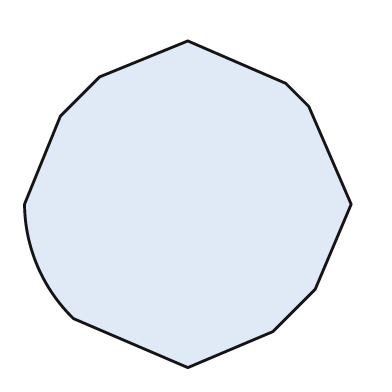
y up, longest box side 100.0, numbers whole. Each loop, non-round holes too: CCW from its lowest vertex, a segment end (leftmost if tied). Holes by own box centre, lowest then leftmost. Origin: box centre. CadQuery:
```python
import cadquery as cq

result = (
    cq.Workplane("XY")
    .moveTo(0.0, -50.0)
    .lineTo(26.0, -39.0)
    .lineTo(39.0, -26.0)
    .lineTo(50.0, 0.0)
    .lineTo(37.0, 30.0)
    .lineTo(30.0, 37.0)
    .lineTo(0.0, 50.0)
    .lineTo(-27.0, 39.0)
    .lineTo(-39.0, 27.0)
    .lineTo(-50.0, 0.0)
    .threePointArc((-46.0, -19.0), (-35.0, -35.0))
    .close()
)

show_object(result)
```